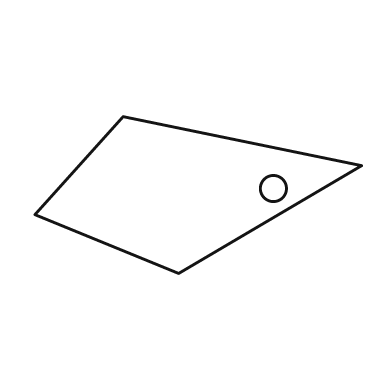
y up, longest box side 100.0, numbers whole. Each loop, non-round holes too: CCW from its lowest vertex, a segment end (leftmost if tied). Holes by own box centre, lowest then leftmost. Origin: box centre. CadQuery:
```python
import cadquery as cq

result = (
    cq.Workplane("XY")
    .moveTo(-6.0, -24.0)
    .lineTo(50.0, 9.0)
    .lineTo(-23.0, 24.0)
    .lineTo(-50.0, -6.0)
    .close()
    .moveTo(23.0, 2.0)
    .circle(4.0)
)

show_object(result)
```